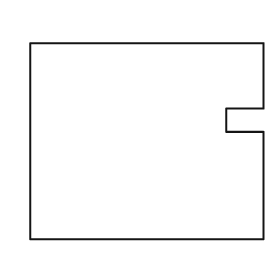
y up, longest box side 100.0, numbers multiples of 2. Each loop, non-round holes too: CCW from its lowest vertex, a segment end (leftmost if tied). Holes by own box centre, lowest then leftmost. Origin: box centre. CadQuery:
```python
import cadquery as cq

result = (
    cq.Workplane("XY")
    .moveTo(-50.0, -42.0)
    .lineTo(50.0, -42.0)
    .lineTo(50.0, 4.0)
    .lineTo(34.0, 4.0)
    .lineTo(34.0, 14.0)
    .lineTo(50.0, 14.0)
    .lineTo(50.0, 42.0)
    .lineTo(-50.0, 42.0)
    .close()
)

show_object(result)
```